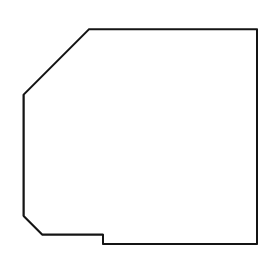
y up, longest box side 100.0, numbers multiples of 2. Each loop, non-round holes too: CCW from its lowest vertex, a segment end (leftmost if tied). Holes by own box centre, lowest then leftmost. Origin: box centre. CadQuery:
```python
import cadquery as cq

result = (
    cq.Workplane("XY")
    .moveTo(-16.0, -46.0)
    .lineTo(50.0, -46.0)
    .lineTo(50.0, 46.0)
    .lineTo(-22.0, 46.0)
    .lineTo(-50.0, 18.0)
    .lineTo(-50.0, -34.0)
    .lineTo(-42.0, -42.0)
    .lineTo(-16.0, -42.0)
    .close()
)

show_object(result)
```